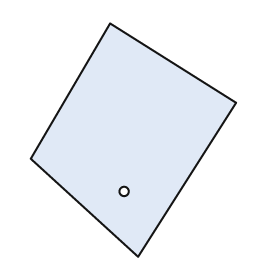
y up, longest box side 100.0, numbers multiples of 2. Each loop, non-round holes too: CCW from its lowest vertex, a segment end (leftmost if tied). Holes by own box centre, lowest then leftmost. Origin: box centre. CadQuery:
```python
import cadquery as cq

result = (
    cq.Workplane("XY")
    .moveTo(2.0, -50.0)
    .lineTo(44.0, 16.0)
    .lineTo(-10.0, 50.0)
    .lineTo(-44.0, -8.0)
    .close()
    .moveTo(-4.0, -22.0)
    .circle(2.0)
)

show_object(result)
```